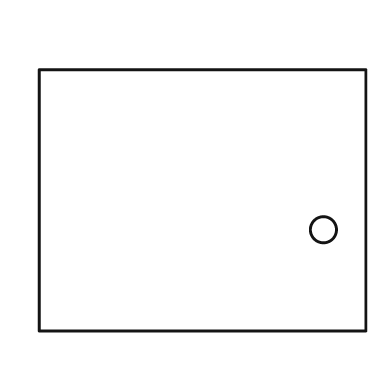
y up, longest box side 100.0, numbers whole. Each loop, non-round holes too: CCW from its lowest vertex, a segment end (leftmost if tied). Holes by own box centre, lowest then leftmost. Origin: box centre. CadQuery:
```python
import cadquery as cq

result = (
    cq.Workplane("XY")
    .moveTo(-50.0, -40.0)
    .lineTo(50.0, -40.0)
    .lineTo(50.0, 40.0)
    .lineTo(-50.0, 40.0)
    .close()
    .moveTo(37.0, -9.0)
    .circle(4.0)
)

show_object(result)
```